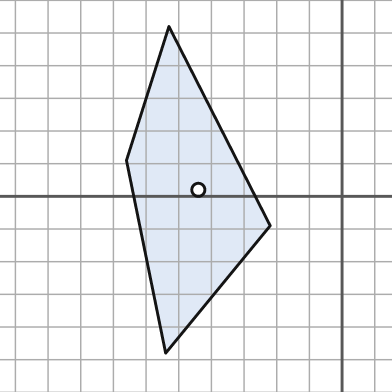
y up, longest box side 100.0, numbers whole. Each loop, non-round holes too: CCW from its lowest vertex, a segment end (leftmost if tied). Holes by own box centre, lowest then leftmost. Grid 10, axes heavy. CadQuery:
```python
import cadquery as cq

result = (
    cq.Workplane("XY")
    .moveTo(-54.0, -48.0)
    .lineTo(-22.0, -9.0)
    .lineTo(-53.0, 52.0)
    .lineTo(-66.0, 11.0)
    .close()
    .moveTo(-44.0, 2.0)
    .circle(2.0)
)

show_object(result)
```